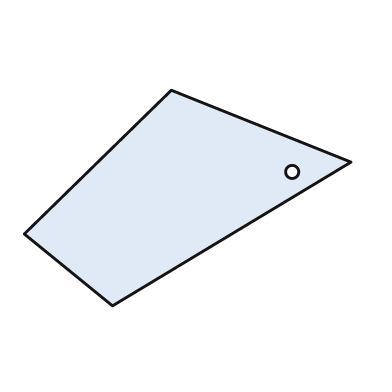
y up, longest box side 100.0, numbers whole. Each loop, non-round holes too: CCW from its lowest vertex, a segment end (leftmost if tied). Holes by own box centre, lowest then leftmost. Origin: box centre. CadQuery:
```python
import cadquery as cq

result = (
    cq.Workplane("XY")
    .moveTo(-23.0, -33.0)
    .lineTo(50.0, 11.0)
    .lineTo(-5.0, 33.0)
    .lineTo(-50.0, -11.0)
    .close()
    .moveTo(32.0, 8.0)
    .circle(2.0)
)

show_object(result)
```